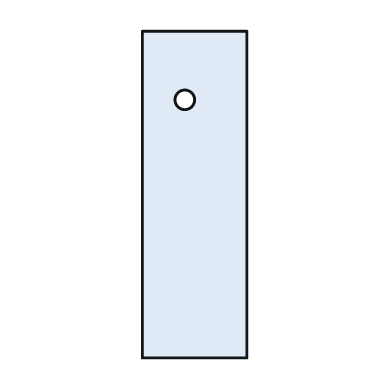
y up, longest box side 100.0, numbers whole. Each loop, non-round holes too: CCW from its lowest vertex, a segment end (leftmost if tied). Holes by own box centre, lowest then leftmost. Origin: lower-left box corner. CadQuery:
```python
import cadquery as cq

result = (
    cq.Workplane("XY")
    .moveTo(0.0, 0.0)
    .lineTo(32.0, 0.0)
    .lineTo(32.0, 100.0)
    .lineTo(0.0, 100.0)
    .close()
    .moveTo(13.0, 79.0)
    .circle(3.0)
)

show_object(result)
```